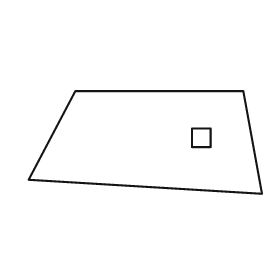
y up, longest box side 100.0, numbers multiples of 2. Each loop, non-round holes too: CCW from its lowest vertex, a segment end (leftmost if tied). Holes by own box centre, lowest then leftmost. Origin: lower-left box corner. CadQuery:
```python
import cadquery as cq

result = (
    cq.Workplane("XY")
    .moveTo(100.0, 0.0)
    .lineTo(92.0, 44.0)
    .lineTo(20.0, 44.0)
    .lineTo(0.0, 6.0)
    .close()
    .moveTo(70.0, 20.0)
    .lineTo(78.0, 20.0)
    .lineTo(78.0, 28.0)
    .lineTo(70.0, 28.0)
    .close()
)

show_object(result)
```